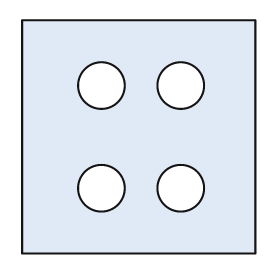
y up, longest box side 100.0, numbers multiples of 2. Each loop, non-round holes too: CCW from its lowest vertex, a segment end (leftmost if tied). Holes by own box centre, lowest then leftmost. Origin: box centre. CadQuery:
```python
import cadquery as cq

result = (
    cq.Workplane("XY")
    .moveTo(-50.0, -50.0)
    .lineTo(50.0, -50.0)
    .lineTo(50.0, 50.0)
    .lineTo(-50.0, 50.0)
    .close()
    .moveTo(-16.0, -22.0)
    .circle(10.0)
    .moveTo(18.0, -22.0)
    .circle(10.0)
    .moveTo(-16.0, 22.0)
    .circle(10.0)
    .moveTo(18.0, 22.0)
    .circle(10.0)
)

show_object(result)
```